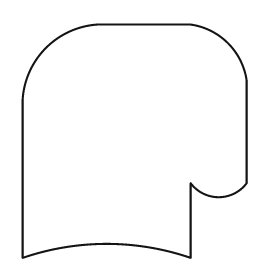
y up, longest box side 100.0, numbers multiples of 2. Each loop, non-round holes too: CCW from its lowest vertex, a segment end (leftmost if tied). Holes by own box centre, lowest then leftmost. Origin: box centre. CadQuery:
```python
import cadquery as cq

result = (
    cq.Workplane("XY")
    .moveTo(-48.0, -50.0)
    .threePointArc((-12.0, -44.0), (24.0, -50.0))
    .lineTo(24.0, -18.0)
    .threePointArc((36.0, -24.0), (48.0, -18.0))
    .lineTo(48.0, 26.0)
    .threePointArc((40.0, 42.0), (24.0, 50.0))
    .lineTo(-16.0, 50.0)
    .threePointArc((-38.0, 40.0), (-48.0, 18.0))
    .close()
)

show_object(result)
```